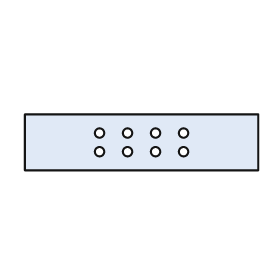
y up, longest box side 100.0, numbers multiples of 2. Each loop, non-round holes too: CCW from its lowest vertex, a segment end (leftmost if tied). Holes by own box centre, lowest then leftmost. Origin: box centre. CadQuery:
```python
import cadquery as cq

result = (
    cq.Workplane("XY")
    .moveTo(-50.0, -12.0)
    .lineTo(50.0, -12.0)
    .lineTo(50.0, 12.0)
    .lineTo(-50.0, 12.0)
    .close()
    .moveTo(-18.0, -4.0)
    .circle(2.0)
    .moveTo(-6.0, -4.0)
    .circle(2.0)
    .moveTo(6.0, -4.0)
    .circle(2.0)
    .moveTo(18.0, -4.0)
    .circle(2.0)
    .moveTo(-18.0, 4.0)
    .circle(2.0)
    .moveTo(-6.0, 4.0)
    .circle(2.0)
    .moveTo(6.0, 4.0)
    .circle(2.0)
    .moveTo(18.0, 4.0)
    .circle(2.0)
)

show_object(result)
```